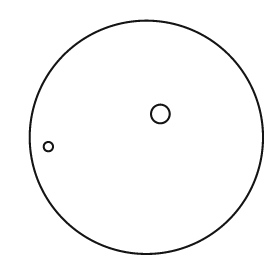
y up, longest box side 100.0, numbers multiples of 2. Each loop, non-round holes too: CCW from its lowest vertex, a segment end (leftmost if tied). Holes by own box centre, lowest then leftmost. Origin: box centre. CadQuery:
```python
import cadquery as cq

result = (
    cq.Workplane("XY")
    .moveTo(0.0, 0.0)
    .circle(50.0)
    .moveTo(-42.0, -4.0)
    .circle(2.0)
    .moveTo(6.0, 10.0)
    .circle(4.0)
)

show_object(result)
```